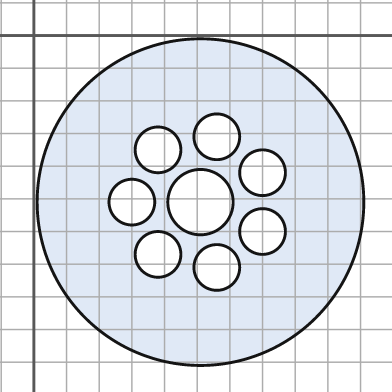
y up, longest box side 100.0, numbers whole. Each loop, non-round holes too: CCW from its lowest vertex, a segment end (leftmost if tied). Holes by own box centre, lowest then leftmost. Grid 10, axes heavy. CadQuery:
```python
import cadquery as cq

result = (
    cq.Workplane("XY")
    .moveTo(51.0, -51.0)
    .circle(50.0)
    .moveTo(56.0, -71.0)
    .circle(7.0)
    .moveTo(38.0, -67.0)
    .circle(7.0)
    .moveTo(70.0, -60.0)
    .circle(7.0)
    .moveTo(30.0, -51.0)
    .circle(7.0)
    .moveTo(51.0, -51.0)
    .circle(10.0)
    .moveTo(70.0, -42.0)
    .circle(7.0)
    .moveTo(38.0, -35.0)
    .circle(7.0)
    .moveTo(56.0, -31.0)
    .circle(7.0)
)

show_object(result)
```